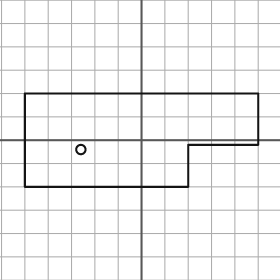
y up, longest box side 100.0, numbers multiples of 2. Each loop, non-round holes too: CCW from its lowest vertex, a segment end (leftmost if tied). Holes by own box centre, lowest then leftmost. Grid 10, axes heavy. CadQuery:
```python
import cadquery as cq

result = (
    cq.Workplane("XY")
    .moveTo(-50.0, -20.0)
    .lineTo(20.0, -20.0)
    .lineTo(20.0, -2.0)
    .lineTo(50.0, -2.0)
    .lineTo(50.0, 20.0)
    .lineTo(-50.0, 20.0)
    .close()
    .moveTo(-26.0, -4.0)
    .circle(2.0)
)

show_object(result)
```